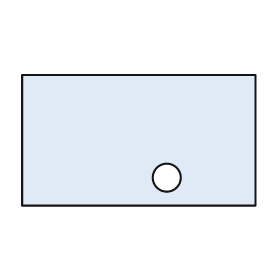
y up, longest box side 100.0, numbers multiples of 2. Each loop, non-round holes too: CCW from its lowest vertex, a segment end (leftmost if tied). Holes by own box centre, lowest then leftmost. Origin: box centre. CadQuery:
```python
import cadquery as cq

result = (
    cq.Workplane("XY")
    .moveTo(-50.0, -28.0)
    .lineTo(50.0, -28.0)
    .lineTo(50.0, 28.0)
    .lineTo(-50.0, 28.0)
    .close()
    .moveTo(12.0, -16.0)
    .circle(6.0)
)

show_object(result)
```